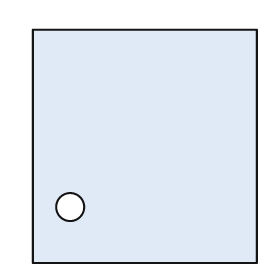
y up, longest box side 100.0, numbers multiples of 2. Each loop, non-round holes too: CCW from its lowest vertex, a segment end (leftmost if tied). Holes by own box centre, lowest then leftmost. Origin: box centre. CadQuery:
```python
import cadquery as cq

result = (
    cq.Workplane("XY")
    .moveTo(-48.0, -50.0)
    .lineTo(48.0, -50.0)
    .lineTo(48.0, 50.0)
    .lineTo(-48.0, 50.0)
    .close()
    .moveTo(-32.0, -26.0)
    .circle(6.0)
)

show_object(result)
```